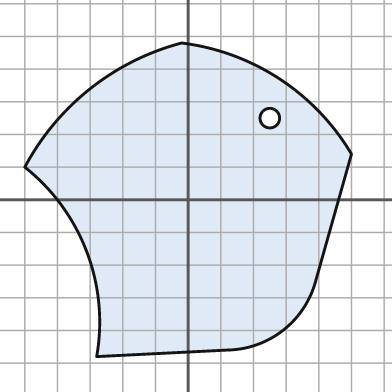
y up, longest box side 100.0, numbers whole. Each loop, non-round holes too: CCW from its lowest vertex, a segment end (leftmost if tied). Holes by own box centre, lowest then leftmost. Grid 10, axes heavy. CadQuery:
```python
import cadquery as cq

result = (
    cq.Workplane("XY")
    .moveTo(-28.0, -48.0)
    .lineTo(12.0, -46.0)
    .threePointArc((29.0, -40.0), (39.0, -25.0))
    .lineTo(50.0, 14.0)
    .threePointArc((28.0, 37.0), (-2.0, 48.0))
    .threePointArc((-30.0, 34.0), (-50.0, 10.0))
    .threePointArc((-31.0, -16.0), (-28.0, -48.0))
    .close()
    .moveTo(25.0, 25.0)
    .circle(3.0)
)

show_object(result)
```